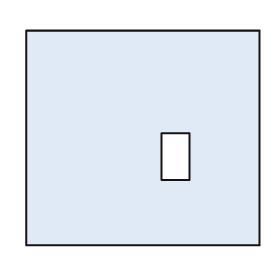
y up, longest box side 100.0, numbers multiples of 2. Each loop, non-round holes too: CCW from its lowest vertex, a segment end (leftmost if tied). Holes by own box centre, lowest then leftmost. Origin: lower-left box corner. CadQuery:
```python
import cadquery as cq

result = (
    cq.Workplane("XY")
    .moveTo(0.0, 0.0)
    .lineTo(100.0, 0.0)
    .lineTo(100.0, 92.0)
    .lineTo(0.0, 92.0)
    .close()
    .moveTo(58.0, 28.0)
    .lineTo(70.0, 28.0)
    .lineTo(70.0, 48.0)
    .lineTo(58.0, 48.0)
    .close()
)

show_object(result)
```